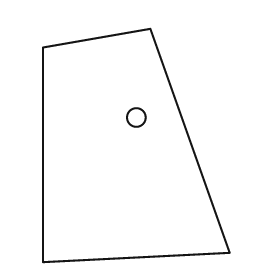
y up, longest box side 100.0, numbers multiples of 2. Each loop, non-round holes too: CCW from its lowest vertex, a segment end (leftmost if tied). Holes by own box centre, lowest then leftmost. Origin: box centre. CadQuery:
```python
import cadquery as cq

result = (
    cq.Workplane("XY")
    .moveTo(-40.0, -50.0)
    .lineTo(40.0, -46.0)
    .lineTo(6.0, 50.0)
    .lineTo(-40.0, 42.0)
    .close()
    .moveTo(0.0, 12.0)
    .circle(4.0)
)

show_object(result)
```